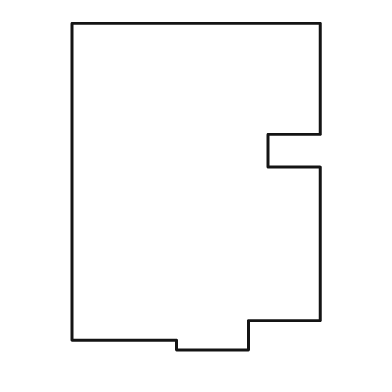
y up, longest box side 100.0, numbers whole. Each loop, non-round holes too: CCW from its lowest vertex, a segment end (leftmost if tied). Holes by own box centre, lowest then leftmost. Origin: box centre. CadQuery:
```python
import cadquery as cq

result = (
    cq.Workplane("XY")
    .moveTo(-6.0, -50.0)
    .lineTo(16.0, -50.0)
    .lineTo(16.0, -41.0)
    .lineTo(38.0, -41.0)
    .lineTo(38.0, 6.0)
    .lineTo(22.0, 6.0)
    .lineTo(22.0, 16.0)
    .lineTo(38.0, 16.0)
    .lineTo(38.0, 50.0)
    .lineTo(-38.0, 50.0)
    .lineTo(-38.0, -47.0)
    .lineTo(-6.0, -47.0)
    .close()
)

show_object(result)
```